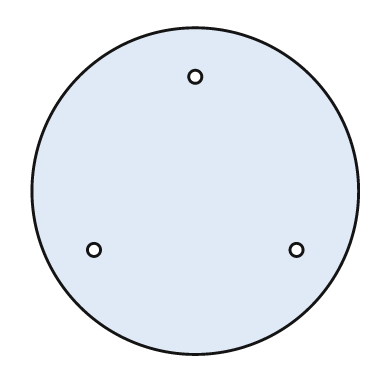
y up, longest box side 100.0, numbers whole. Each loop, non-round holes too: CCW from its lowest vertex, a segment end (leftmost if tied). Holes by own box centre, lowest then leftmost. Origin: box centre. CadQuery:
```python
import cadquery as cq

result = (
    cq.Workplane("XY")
    .moveTo(0.0, 0.0)
    .circle(50.0)
    .moveTo(-31.0, -18.0)
    .circle(2.0)
    .moveTo(31.0, -18.0)
    .circle(2.0)
    .moveTo(0.0, 35.0)
    .circle(2.0)
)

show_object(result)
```